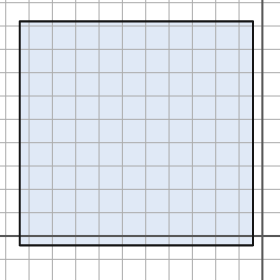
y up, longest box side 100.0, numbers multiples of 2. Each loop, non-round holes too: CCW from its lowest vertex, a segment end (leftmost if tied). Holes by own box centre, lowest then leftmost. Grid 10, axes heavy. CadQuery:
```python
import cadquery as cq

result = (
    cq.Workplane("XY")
    .moveTo(-104.0, -4.0)
    .lineTo(-4.0, -4.0)
    .lineTo(-4.0, 92.0)
    .lineTo(-104.0, 92.0)
    .close()
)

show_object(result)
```